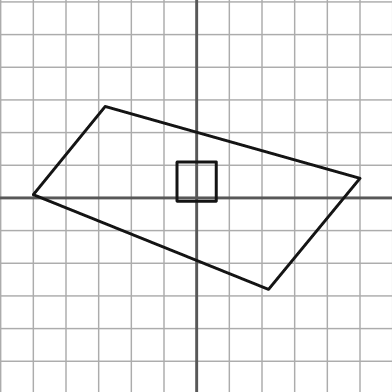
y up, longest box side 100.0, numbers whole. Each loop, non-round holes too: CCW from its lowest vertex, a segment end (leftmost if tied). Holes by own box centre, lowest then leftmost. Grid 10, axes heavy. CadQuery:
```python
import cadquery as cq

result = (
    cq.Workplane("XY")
    .moveTo(22.0, -28.0)
    .lineTo(50.0, 6.0)
    .lineTo(-28.0, 28.0)
    .lineTo(-50.0, 1.0)
    .close()
    .moveTo(-6.0, -1.0)
    .lineTo(6.0, -1.0)
    .lineTo(6.0, 11.0)
    .lineTo(-6.0, 11.0)
    .close()
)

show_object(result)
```